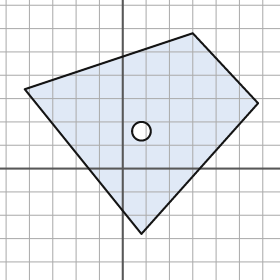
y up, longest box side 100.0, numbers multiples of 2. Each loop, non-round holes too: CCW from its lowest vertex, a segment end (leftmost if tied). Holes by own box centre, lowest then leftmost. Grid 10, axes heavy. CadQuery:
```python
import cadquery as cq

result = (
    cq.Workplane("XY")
    .moveTo(8.0, -28.0)
    .lineTo(58.0, 28.0)
    .lineTo(30.0, 58.0)
    .lineTo(-42.0, 34.0)
    .close()
    .moveTo(8.0, 16.0)
    .circle(4.0)
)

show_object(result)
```